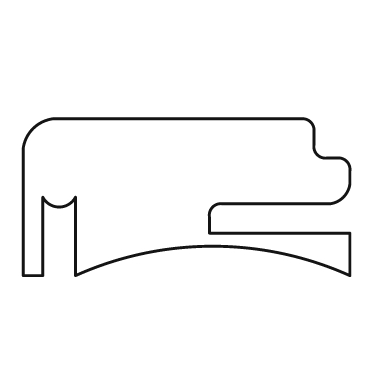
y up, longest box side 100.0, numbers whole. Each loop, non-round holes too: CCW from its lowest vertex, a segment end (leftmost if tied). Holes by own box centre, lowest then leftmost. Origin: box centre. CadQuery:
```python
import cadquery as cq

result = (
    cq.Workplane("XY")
    .moveTo(-50.0, -24.0)
    .lineTo(-44.0, -24.0)
    .lineTo(-44.0, 0.0)
    .threePointArc((-39.0, -3.0), (-34.0, 0.0))
    .lineTo(-34.0, -24.0)
    .threePointArc((8.0, -15.0), (50.0, -24.0))
    .lineTo(50.0, -11.0)
    .lineTo(7.0, -11.0)
    .lineTo(7.0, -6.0)
    .threePointArc((8.0, -3.0), (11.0, -2.0))
    .lineTo(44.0, -2.0)
    .threePointArc((48.0, 0.0), (50.0, 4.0))
    .lineTo(50.0, 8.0)
    .threePointArc((49.0, 11.0), (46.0, 12.0))
    .lineTo(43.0, 12.0)
    .threePointArc((40.0, 13.0), (39.0, 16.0))
    .lineTo(39.0, 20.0)
    .threePointArc((38.0, 23.0), (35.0, 24.0))
    .lineTo(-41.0, 24.0)
    .threePointArc((-47.0, 21.0), (-50.0, 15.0))
    .close()
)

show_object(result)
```